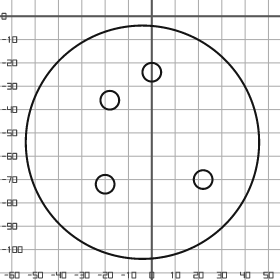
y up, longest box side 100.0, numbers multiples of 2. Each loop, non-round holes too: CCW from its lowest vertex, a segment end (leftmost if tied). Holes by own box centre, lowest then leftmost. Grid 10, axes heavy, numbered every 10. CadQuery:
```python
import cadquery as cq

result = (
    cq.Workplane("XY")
    .moveTo(-4.0, -54.0)
    .circle(50.0)
    .moveTo(-20.0, -72.0)
    .circle(4.0)
    .moveTo(22.0, -70.0)
    .circle(4.0)
    .moveTo(-18.0, -36.0)
    .circle(4.0)
    .moveTo(0.0, -24.0)
    .circle(4.0)
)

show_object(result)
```